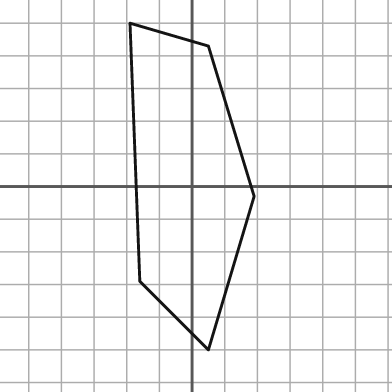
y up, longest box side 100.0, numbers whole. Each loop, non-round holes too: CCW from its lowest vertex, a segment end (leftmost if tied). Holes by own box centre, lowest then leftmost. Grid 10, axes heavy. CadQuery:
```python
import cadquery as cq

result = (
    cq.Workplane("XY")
    .moveTo(5.0, -50.0)
    .lineTo(19.0, -3.0)
    .lineTo(5.0, 43.0)
    .lineTo(-19.0, 50.0)
    .lineTo(-16.0, -29.0)
    .close()
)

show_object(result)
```